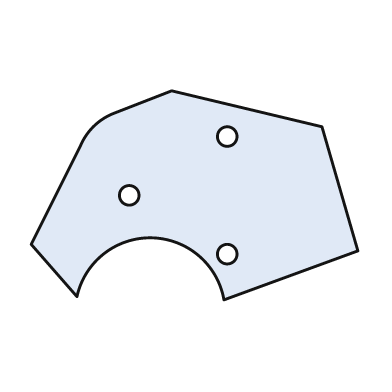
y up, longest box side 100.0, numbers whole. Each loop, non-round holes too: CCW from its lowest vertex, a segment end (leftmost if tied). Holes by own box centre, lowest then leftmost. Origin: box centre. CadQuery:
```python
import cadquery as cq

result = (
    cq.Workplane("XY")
    .moveTo(9.0, -32.0)
    .lineTo(50.0, -17.0)
    .lineTo(39.0, 21.0)
    .lineTo(-7.0, 32.0)
    .lineTo(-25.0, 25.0)
    .threePointArc((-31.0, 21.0), (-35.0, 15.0))
    .lineTo(-50.0, -15.0)
    .lineTo(-36.0, -31.0)
    .threePointArc((-13.0, -13.0), (9.0, -32.0))
    .close()
    .moveTo(10.0, -18.0)
    .circle(3.0)
    .moveTo(-20.0, 0.0)
    .circle(3.0)
    .moveTo(10.0, 18.0)
    .circle(3.0)
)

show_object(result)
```